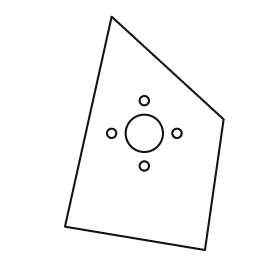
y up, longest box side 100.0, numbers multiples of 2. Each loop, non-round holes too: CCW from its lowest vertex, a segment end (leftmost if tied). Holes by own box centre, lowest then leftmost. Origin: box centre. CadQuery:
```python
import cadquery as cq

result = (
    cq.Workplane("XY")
    .moveTo(26.0, -50.0)
    .lineTo(34.0, 6.0)
    .lineTo(-14.0, 50.0)
    .lineTo(-34.0, -40.0)
    .close()
    .moveTo(0.0, -14.0)
    .circle(2.0)
    .moveTo(-14.0, 0.0)
    .circle(2.0)
    .moveTo(0.0, 0.0)
    .circle(8.0)
    .moveTo(14.0, 0.0)
    .circle(2.0)
    .moveTo(0.0, 14.0)
    .circle(2.0)
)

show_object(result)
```